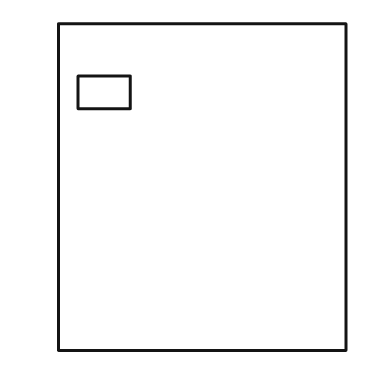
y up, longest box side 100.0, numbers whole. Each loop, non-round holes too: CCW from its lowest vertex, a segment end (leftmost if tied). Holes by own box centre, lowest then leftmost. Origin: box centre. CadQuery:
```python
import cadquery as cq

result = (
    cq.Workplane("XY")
    .moveTo(-44.0, -50.0)
    .lineTo(44.0, -50.0)
    .lineTo(44.0, 50.0)
    .lineTo(-44.0, 50.0)
    .close()
    .moveTo(-38.0, 24.0)
    .lineTo(-22.0, 24.0)
    .lineTo(-22.0, 34.0)
    .lineTo(-38.0, 34.0)
    .close()
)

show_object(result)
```